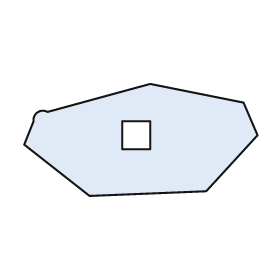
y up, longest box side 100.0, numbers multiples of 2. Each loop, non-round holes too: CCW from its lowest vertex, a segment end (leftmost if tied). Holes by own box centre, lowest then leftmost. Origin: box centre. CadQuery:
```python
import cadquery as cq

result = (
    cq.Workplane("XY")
    .moveTo(-22.0, -24.0)
    .lineTo(28.0, -22.0)
    .lineTo(50.0, 2.0)
    .lineTo(44.0, 16.0)
    .lineTo(4.0, 24.0)
    .lineTo(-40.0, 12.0)
    .threePointArc((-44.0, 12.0), (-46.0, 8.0))
    .lineTo(-50.0, -2.0)
    .close()
    .moveTo(-8.0, -4.0)
    .lineTo(4.0, -4.0)
    .lineTo(4.0, 8.0)
    .lineTo(-8.0, 8.0)
    .close()
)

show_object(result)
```